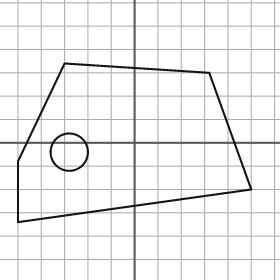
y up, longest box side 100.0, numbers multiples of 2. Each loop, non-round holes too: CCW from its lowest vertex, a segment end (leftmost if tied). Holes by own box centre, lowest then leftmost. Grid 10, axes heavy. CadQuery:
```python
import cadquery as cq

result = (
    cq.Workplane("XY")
    .moveTo(-50.0, -34.0)
    .lineTo(50.0, -20.0)
    .lineTo(32.0, 30.0)
    .lineTo(-30.0, 34.0)
    .lineTo(-50.0, -8.0)
    .close()
    .moveTo(-28.0, -4.0)
    .circle(8.0)
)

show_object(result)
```